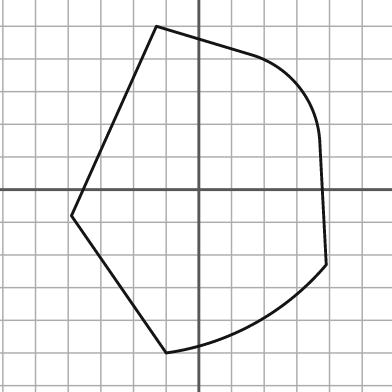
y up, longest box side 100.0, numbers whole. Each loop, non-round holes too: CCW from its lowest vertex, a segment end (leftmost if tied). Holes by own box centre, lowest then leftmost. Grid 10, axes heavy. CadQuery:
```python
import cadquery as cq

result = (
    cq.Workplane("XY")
    .moveTo(-10.0, -50.0)
    .threePointArc((17.0, -41.0), (39.0, -23.0))
    .lineTo(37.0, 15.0)
    .threePointArc((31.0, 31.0), (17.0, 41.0))
    .lineTo(-13.0, 50.0)
    .lineTo(-39.0, -8.0)
    .close()
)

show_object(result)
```